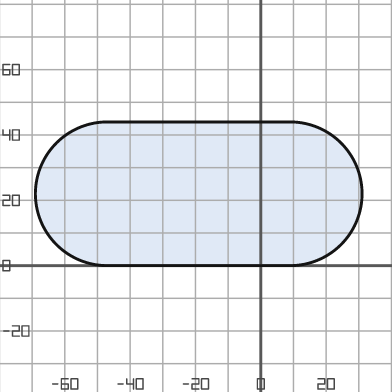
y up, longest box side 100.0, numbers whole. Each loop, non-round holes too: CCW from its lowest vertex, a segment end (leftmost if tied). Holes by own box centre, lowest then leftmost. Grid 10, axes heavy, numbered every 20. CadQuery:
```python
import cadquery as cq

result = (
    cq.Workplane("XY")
    .moveTo(-47.0, 0.0)
    .lineTo(9.0, 0.0)
    .threePointArc((31.0, 22.0), (9.0, 44.0))
    .lineTo(-47.0, 44.0)
    .threePointArc((-69.0, 22.0), (-47.0, 0.0))
    .close()
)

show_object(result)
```